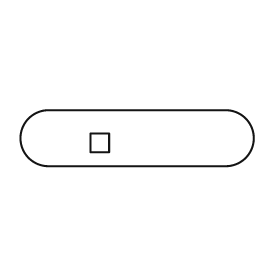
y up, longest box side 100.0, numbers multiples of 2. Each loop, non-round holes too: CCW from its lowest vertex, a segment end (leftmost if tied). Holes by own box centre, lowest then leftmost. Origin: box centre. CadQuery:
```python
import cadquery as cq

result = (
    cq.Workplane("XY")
    .moveTo(-38.0, -12.0)
    .lineTo(38.0, -12.0)
    .threePointArc((50.0, 0.0), (38.0, 12.0))
    .lineTo(-38.0, 12.0)
    .threePointArc((-50.0, 0.0), (-38.0, -12.0))
    .close()
    .moveTo(-20.0, -6.0)
    .lineTo(-12.0, -6.0)
    .lineTo(-12.0, 2.0)
    .lineTo(-20.0, 2.0)
    .close()
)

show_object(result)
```